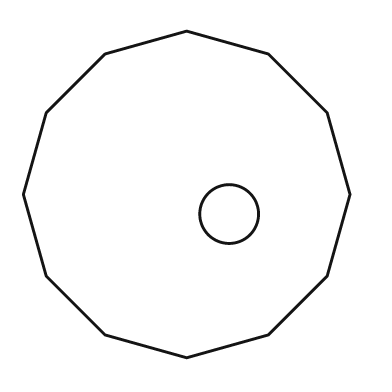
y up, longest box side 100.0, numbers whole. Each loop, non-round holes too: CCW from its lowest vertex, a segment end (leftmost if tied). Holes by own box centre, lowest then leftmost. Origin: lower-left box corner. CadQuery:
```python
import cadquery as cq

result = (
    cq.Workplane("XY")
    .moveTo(50.0, 0.0)
    .lineTo(75.0, 7.0)
    .lineTo(93.0, 25.0)
    .lineTo(100.0, 50.0)
    .lineTo(93.0, 75.0)
    .lineTo(75.0, 93.0)
    .lineTo(50.0, 100.0)
    .lineTo(25.0, 93.0)
    .lineTo(7.0, 75.0)
    .lineTo(0.0, 50.0)
    .lineTo(7.0, 25.0)
    .lineTo(25.0, 7.0)
    .close()
    .moveTo(63.0, 44.0)
    .circle(9.0)
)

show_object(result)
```